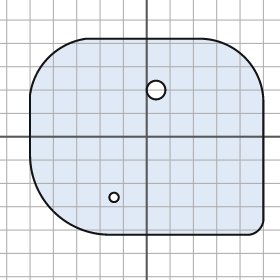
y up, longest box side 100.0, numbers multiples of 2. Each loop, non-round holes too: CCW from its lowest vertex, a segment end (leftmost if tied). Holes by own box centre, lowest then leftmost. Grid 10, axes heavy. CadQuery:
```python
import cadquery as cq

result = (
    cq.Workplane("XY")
    .moveTo(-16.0, -42.0)
    .lineTo(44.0, -42.0)
    .threePointArc((48.0, -40.0), (50.0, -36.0))
    .lineTo(50.0, 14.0)
    .threePointArc((42.0, 34.0), (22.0, 42.0))
    .lineTo(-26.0, 42.0)
    .threePointArc((-42.0, 34.0), (-50.0, 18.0))
    .lineTo(-50.0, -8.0)
    .threePointArc((-40.0, -32.0), (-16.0, -42.0))
    .close()
    .moveTo(-14.0, -26.0)
    .circle(2.0)
    .moveTo(4.0, 20.0)
    .circle(4.0)
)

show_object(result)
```